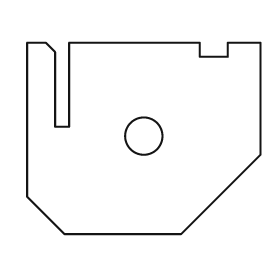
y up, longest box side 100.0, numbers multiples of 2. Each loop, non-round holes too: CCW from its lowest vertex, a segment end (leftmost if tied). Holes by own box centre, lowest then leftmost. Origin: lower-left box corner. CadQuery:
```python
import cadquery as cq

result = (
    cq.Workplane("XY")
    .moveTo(16.0, 0.0)
    .lineTo(66.0, 0.0)
    .lineTo(100.0, 34.0)
    .lineTo(100.0, 82.0)
    .lineTo(86.0, 82.0)
    .lineTo(86.0, 76.0)
    .lineTo(74.0, 76.0)
    .lineTo(74.0, 82.0)
    .lineTo(18.0, 82.0)
    .lineTo(18.0, 46.0)
    .lineTo(12.0, 46.0)
    .lineTo(12.0, 78.0)
    .lineTo(8.0, 82.0)
    .lineTo(0.0, 82.0)
    .lineTo(0.0, 16.0)
    .close()
    .moveTo(50.0, 42.0)
    .circle(8.0)
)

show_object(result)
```